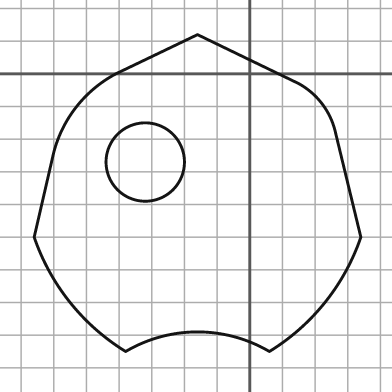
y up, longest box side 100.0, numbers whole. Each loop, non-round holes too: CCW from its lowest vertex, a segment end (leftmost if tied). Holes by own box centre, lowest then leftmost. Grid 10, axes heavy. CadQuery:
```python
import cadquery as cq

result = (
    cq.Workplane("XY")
    .moveTo(-38.0, -85.0)
    .threePointArc((-16.0, -79.0), (6.0, -85.0))
    .threePointArc((23.0, -70.0), (34.0, -50.0))
    .lineTo(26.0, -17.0)
    .threePointArc((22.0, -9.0), (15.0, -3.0))
    .lineTo(-16.0, 12.0)
    .lineTo(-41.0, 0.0)
    .threePointArc((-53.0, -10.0), (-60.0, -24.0))
    .lineTo(-66.0, -50.0)
    .threePointArc((-55.0, -70.0), (-38.0, -85.0))
    .close()
    .moveTo(-32.0, -27.0)
    .circle(12.0)
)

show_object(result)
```